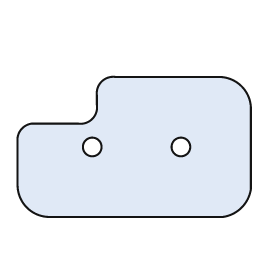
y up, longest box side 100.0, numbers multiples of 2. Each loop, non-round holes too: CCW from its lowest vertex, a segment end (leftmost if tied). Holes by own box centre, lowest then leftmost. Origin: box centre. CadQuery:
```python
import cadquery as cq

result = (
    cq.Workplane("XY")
    .moveTo(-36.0, -30.0)
    .lineTo(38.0, -30.0)
    .threePointArc((46.0, -26.0), (50.0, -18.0))
    .lineTo(50.0, 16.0)
    .threePointArc((46.0, 26.0), (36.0, 30.0))
    .lineTo(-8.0, 30.0)
    .threePointArc((-14.0, 28.0), (-16.0, 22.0))
    .lineTo(-16.0, 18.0)
    .threePointArc((-18.0, 12.0), (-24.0, 10.0))
    .lineTo(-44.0, 10.0)
    .threePointArc((-48.0, 8.0), (-50.0, 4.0))
    .lineTo(-50.0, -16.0)
    .threePointArc((-46.0, -26.0), (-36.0, -30.0))
    .close()
    .moveTo(-18.0, 0.0)
    .circle(4.0)
    .moveTo(20.0, 0.0)
    .circle(4.0)
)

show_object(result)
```